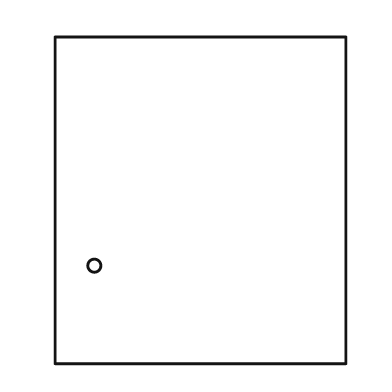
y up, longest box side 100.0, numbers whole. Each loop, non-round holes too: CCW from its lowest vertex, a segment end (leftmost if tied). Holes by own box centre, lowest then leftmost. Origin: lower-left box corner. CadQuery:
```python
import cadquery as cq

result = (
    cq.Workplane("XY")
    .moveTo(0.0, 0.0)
    .lineTo(89.0, 0.0)
    .lineTo(89.0, 100.0)
    .lineTo(0.0, 100.0)
    .close()
    .moveTo(12.0, 30.0)
    .circle(2.0)
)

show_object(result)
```